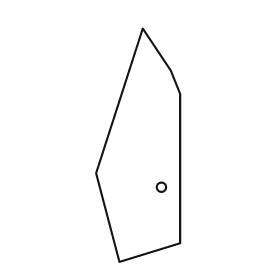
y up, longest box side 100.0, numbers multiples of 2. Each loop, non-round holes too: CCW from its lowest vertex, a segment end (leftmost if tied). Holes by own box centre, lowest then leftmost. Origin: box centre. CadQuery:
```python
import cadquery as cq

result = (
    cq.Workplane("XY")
    .moveTo(-8.0, -50.0)
    .lineTo(18.0, -42.0)
    .lineTo(18.0, 22.0)
    .lineTo(14.0, 32.0)
    .lineTo(2.0, 50.0)
    .lineTo(-18.0, -12.0)
    .close()
    .moveTo(10.0, -18.0)
    .circle(2.0)
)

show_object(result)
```